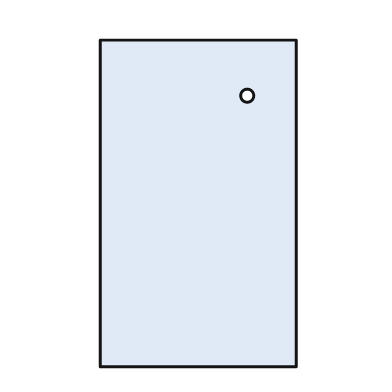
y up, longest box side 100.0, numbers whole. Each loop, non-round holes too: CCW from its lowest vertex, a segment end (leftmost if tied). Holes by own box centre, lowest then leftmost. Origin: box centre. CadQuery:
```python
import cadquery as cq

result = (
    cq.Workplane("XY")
    .moveTo(-30.0, -50.0)
    .lineTo(30.0, -50.0)
    .lineTo(30.0, 50.0)
    .lineTo(-30.0, 50.0)
    .close()
    .moveTo(15.0, 33.0)
    .circle(2.0)
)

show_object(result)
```